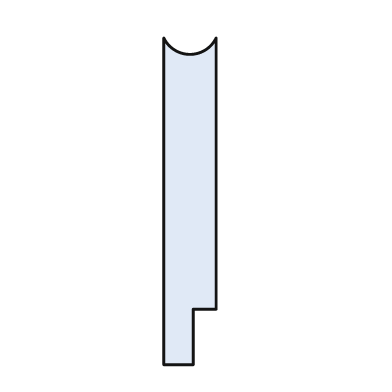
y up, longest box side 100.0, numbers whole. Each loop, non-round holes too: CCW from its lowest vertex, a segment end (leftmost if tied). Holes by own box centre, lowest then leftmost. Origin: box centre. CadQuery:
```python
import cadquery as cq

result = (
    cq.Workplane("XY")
    .moveTo(-8.0, -50.0)
    .lineTo(1.0, -50.0)
    .lineTo(1.0, -33.0)
    .lineTo(8.0, -33.0)
    .lineTo(8.0, 50.0)
    .threePointArc((0.0, 45.0), (-8.0, 50.0))
    .close()
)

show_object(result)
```